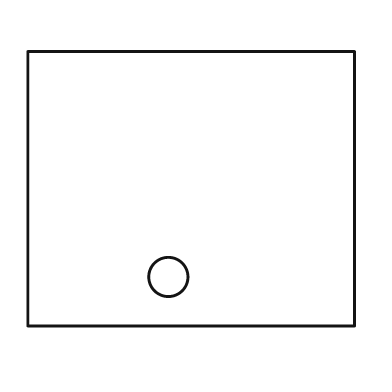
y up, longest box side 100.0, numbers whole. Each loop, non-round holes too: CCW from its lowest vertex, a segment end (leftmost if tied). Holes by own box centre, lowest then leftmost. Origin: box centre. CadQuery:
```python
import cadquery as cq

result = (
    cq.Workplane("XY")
    .moveTo(-50.0, -42.0)
    .lineTo(50.0, -42.0)
    .lineTo(50.0, 42.0)
    .lineTo(-50.0, 42.0)
    .close()
    .moveTo(-7.0, -27.0)
    .circle(6.0)
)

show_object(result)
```